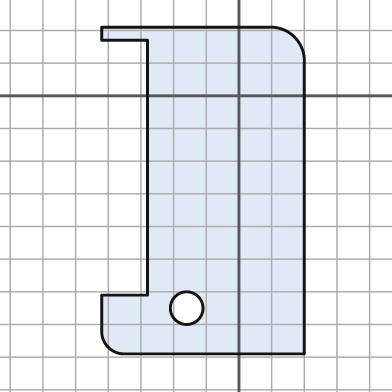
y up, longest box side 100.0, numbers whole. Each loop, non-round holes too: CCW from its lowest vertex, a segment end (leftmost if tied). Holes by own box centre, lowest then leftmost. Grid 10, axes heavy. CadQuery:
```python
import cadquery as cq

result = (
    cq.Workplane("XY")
    .moveTo(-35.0, -79.0)
    .lineTo(20.0, -79.0)
    .lineTo(20.0, 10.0)
    .threePointArc((17.0, 18.0), (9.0, 21.0))
    .lineTo(-42.0, 21.0)
    .lineTo(-42.0, 17.0)
    .lineTo(-28.0, 17.0)
    .lineTo(-28.0, -61.0)
    .lineTo(-42.0, -61.0)
    .lineTo(-42.0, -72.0)
    .threePointArc((-40.0, -77.0), (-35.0, -79.0))
    .close()
    .moveTo(-16.0, -65.0)
    .circle(5.0)
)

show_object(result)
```